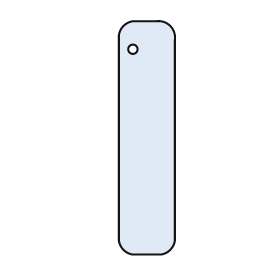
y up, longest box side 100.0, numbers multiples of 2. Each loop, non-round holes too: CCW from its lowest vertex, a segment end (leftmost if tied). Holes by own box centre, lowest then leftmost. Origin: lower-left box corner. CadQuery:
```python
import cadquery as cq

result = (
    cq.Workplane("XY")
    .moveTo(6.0, 0.0)
    .lineTo(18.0, 0.0)
    .threePointArc((22.0, 2.0), (24.0, 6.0))
    .lineTo(24.0, 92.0)
    .threePointArc((22.0, 98.0), (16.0, 100.0))
    .lineTo(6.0, 100.0)
    .threePointArc((2.0, 98.0), (0.0, 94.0))
    .lineTo(0.0, 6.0)
    .threePointArc((2.0, 2.0), (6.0, 0.0))
    .close()
    .moveTo(6.0, 88.0)
    .circle(2.0)
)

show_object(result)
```